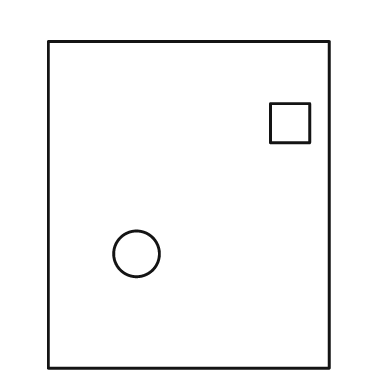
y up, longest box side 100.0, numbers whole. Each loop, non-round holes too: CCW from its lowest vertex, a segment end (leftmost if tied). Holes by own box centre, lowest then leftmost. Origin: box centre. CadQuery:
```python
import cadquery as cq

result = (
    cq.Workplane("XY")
    .moveTo(-43.0, -50.0)
    .lineTo(43.0, -50.0)
    .lineTo(43.0, 50.0)
    .lineTo(-43.0, 50.0)
    .close()
    .moveTo(-16.0, -15.0)
    .circle(7.0)
    .moveTo(25.0, 19.0)
    .lineTo(37.0, 19.0)
    .lineTo(37.0, 31.0)
    .lineTo(25.0, 31.0)
    .close()
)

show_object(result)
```